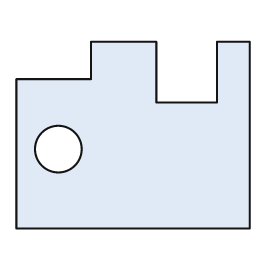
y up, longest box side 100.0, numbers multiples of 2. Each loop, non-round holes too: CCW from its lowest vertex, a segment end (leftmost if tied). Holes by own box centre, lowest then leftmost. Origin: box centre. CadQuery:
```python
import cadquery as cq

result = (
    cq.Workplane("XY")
    .moveTo(-50.0, -40.0)
    .lineTo(50.0, -40.0)
    .lineTo(50.0, 40.0)
    .lineTo(36.0, 40.0)
    .lineTo(36.0, 14.0)
    .lineTo(10.0, 14.0)
    .lineTo(10.0, 40.0)
    .lineTo(-18.0, 40.0)
    .lineTo(-18.0, 24.0)
    .lineTo(-50.0, 24.0)
    .close()
    .moveTo(-32.0, -6.0)
    .circle(10.0)
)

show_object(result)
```